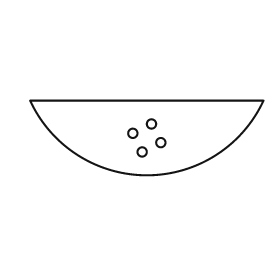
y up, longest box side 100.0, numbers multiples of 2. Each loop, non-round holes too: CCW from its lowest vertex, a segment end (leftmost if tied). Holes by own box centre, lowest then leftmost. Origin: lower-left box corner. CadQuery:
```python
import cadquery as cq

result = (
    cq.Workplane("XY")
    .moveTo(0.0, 32.0)
    .threePointArc((50.0, 0.0), (100.0, 32.0))
    .close()
    .moveTo(48.0, 10.0)
    .circle(2.0)
    .moveTo(56.0, 14.0)
    .circle(2.0)
    .moveTo(44.0, 18.0)
    .circle(2.0)
    .moveTo(52.0, 22.0)
    .circle(2.0)
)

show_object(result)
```